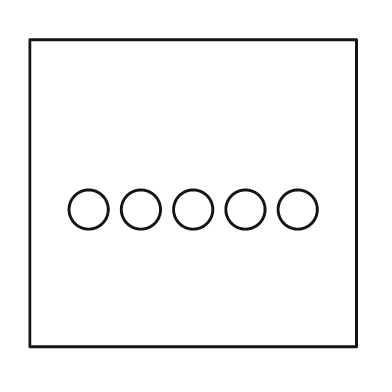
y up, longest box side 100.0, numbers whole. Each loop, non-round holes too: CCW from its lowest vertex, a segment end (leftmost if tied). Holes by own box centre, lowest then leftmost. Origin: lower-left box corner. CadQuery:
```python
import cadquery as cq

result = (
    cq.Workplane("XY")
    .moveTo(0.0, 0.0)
    .lineTo(100.0, 0.0)
    .lineTo(100.0, 94.0)
    .lineTo(0.0, 94.0)
    .close()
    .moveTo(18.0, 42.0)
    .circle(6.0)
    .moveTo(34.0, 42.0)
    .circle(6.0)
    .moveTo(50.0, 42.0)
    .circle(6.0)
    .moveTo(66.0, 42.0)
    .circle(6.0)
    .moveTo(82.0, 42.0)
    .circle(6.0)
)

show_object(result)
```